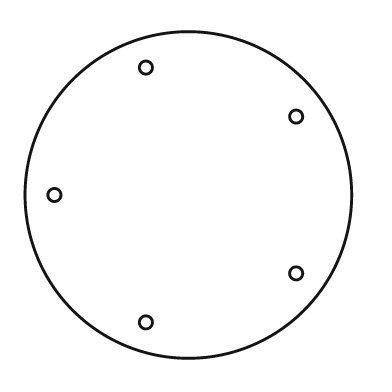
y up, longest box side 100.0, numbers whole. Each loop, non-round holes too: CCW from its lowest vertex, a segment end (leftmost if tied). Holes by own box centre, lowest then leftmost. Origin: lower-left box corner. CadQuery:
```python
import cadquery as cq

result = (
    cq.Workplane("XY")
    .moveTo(50.0, 50.0)
    .circle(50.0)
    .moveTo(37.0, 11.0)
    .circle(2.0)
    .moveTo(83.0, 26.0)
    .circle(2.0)
    .moveTo(9.0, 50.0)
    .circle(2.0)
    .moveTo(83.0, 74.0)
    .circle(2.0)
    .moveTo(37.0, 89.0)
    .circle(2.0)
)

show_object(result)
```